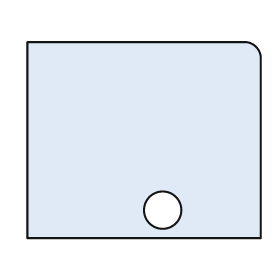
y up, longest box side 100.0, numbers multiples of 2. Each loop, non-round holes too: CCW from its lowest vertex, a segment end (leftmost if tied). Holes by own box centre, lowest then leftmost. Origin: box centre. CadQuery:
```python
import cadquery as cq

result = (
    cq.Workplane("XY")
    .moveTo(-50.0, -42.0)
    .lineTo(50.0, -42.0)
    .lineTo(50.0, 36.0)
    .threePointArc((48.0, 40.0), (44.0, 42.0))
    .lineTo(-50.0, 42.0)
    .close()
    .moveTo(8.0, -30.0)
    .circle(8.0)
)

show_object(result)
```